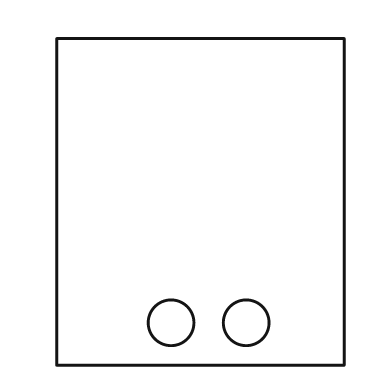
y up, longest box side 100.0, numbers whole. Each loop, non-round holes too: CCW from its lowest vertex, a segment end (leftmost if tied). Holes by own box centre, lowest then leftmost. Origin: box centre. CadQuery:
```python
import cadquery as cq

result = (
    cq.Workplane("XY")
    .moveTo(-44.0, -50.0)
    .lineTo(44.0, -50.0)
    .lineTo(44.0, 50.0)
    .lineTo(-44.0, 50.0)
    .close()
    .moveTo(-9.0, -37.0)
    .circle(7.0)
    .moveTo(14.0, -37.0)
    .circle(7.0)
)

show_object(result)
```